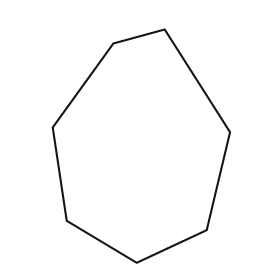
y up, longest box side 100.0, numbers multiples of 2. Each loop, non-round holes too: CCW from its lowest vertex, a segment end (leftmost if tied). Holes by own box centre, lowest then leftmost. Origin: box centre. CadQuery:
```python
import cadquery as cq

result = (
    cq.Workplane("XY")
    .moveTo(-2.0, -50.0)
    .lineTo(28.0, -36.0)
    .lineTo(38.0, 6.0)
    .lineTo(10.0, 50.0)
    .lineTo(-12.0, 44.0)
    .lineTo(-38.0, 8.0)
    .lineTo(-32.0, -32.0)
    .close()
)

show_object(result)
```